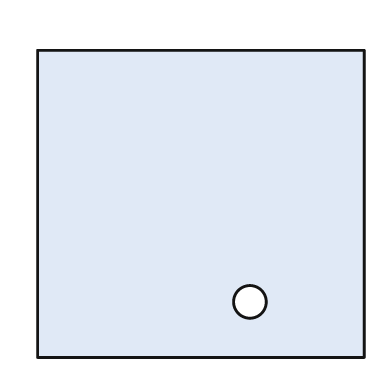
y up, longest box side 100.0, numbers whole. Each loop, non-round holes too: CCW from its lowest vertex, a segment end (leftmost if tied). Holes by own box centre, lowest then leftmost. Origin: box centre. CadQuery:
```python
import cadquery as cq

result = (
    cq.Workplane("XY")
    .moveTo(-50.0, -47.0)
    .lineTo(50.0, -47.0)
    .lineTo(50.0, 47.0)
    .lineTo(-50.0, 47.0)
    .close()
    .moveTo(15.0, -30.0)
    .circle(5.0)
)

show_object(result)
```